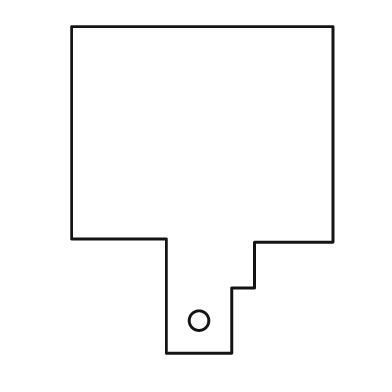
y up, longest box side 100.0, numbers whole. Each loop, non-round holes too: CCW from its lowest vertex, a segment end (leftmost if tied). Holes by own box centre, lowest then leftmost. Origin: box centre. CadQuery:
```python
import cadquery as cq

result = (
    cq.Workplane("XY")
    .moveTo(-11.0, -50.0)
    .lineTo(9.0, -50.0)
    .lineTo(9.0, -30.0)
    .lineTo(16.0, -30.0)
    .lineTo(16.0, -16.0)
    .lineTo(40.0, -16.0)
    .lineTo(40.0, 50.0)
    .lineTo(-40.0, 50.0)
    .lineTo(-40.0, -15.0)
    .lineTo(-11.0, -15.0)
    .close()
    .moveTo(-1.0, -40.0)
    .circle(3.0)
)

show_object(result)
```